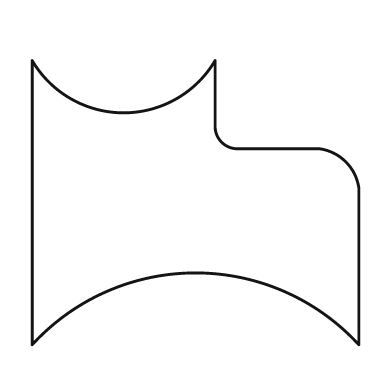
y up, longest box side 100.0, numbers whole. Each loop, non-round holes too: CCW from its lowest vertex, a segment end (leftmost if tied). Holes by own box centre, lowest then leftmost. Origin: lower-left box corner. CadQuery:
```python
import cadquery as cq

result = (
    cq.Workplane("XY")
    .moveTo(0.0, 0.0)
    .threePointArc((50.0, 22.0), (100.0, 0.0))
    .lineTo(100.0, 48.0)
    .threePointArc((96.0, 56.0), (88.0, 60.0))
    .lineTo(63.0, 60.0)
    .threePointArc((58.0, 62.0), (56.0, 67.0))
    .lineTo(56.0, 87.0)
    .threePointArc((28.0, 71.0), (0.0, 87.0))
    .close()
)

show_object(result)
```